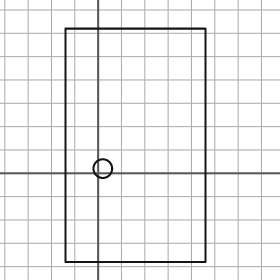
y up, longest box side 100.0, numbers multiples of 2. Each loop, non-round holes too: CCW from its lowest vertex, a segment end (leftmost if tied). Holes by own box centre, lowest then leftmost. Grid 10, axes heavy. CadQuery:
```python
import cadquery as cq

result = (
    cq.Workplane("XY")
    .moveTo(-14.0, -38.0)
    .lineTo(46.0, -38.0)
    .lineTo(46.0, 62.0)
    .lineTo(-14.0, 62.0)
    .close()
    .moveTo(2.0, 2.0)
    .circle(4.0)
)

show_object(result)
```